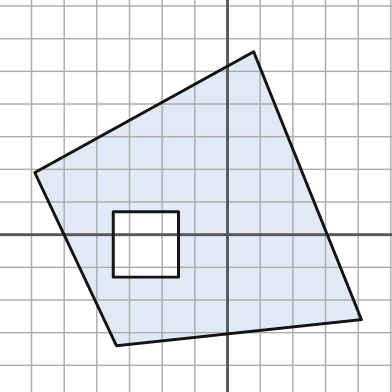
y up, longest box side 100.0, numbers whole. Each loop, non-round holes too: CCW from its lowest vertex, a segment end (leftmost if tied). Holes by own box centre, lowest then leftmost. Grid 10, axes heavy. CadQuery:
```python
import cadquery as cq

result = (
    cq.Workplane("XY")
    .moveTo(-34.0, -34.0)
    .lineTo(41.0, -26.0)
    .lineTo(8.0, 56.0)
    .lineTo(-59.0, 19.0)
    .close()
    .moveTo(-35.0, -13.0)
    .lineTo(-15.0, -13.0)
    .lineTo(-15.0, 7.0)
    .lineTo(-35.0, 7.0)
    .close()
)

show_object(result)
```